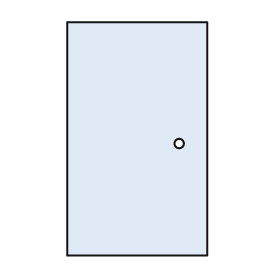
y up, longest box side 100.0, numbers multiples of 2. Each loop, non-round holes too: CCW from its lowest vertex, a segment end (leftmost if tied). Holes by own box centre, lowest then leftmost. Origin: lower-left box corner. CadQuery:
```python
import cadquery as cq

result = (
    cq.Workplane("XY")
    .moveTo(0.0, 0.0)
    .lineTo(60.0, 0.0)
    .lineTo(60.0, 100.0)
    .lineTo(0.0, 100.0)
    .close()
    .moveTo(48.0, 48.0)
    .circle(2.0)
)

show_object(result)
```